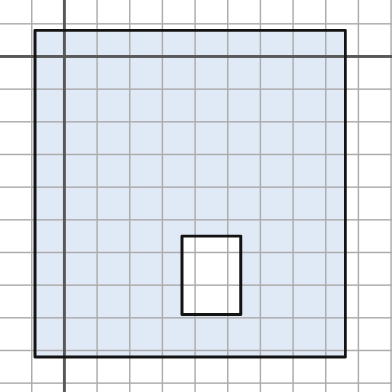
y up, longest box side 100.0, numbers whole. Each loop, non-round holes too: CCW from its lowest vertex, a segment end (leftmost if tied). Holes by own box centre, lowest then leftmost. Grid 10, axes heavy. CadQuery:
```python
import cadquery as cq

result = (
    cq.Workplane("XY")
    .moveTo(-9.0, -92.0)
    .lineTo(86.0, -92.0)
    .lineTo(86.0, 8.0)
    .lineTo(-9.0, 8.0)
    .close()
    .moveTo(36.0, -79.0)
    .lineTo(54.0, -79.0)
    .lineTo(54.0, -55.0)
    .lineTo(36.0, -55.0)
    .close()
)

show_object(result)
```